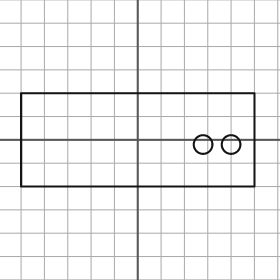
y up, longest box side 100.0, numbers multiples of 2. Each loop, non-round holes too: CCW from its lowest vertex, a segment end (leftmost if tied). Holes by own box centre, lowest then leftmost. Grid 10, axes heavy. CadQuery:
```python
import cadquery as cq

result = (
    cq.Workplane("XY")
    .moveTo(-50.0, -20.0)
    .lineTo(50.0, -20.0)
    .lineTo(50.0, 20.0)
    .lineTo(-50.0, 20.0)
    .close()
    .moveTo(28.0, -2.0)
    .circle(4.0)
    .moveTo(40.0, -2.0)
    .circle(4.0)
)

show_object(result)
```